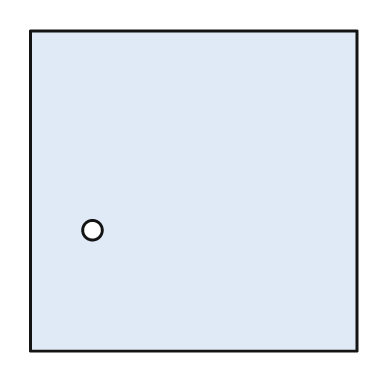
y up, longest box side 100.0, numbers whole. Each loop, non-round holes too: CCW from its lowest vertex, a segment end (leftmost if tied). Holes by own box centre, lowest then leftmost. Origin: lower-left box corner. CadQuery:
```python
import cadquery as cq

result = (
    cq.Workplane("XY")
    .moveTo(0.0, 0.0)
    .lineTo(100.0, 0.0)
    .lineTo(100.0, 98.0)
    .lineTo(0.0, 98.0)
    .close()
    .moveTo(19.0, 37.0)
    .circle(3.0)
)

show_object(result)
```